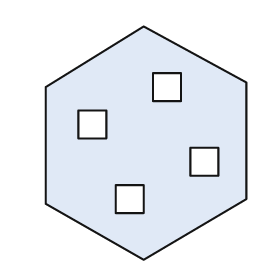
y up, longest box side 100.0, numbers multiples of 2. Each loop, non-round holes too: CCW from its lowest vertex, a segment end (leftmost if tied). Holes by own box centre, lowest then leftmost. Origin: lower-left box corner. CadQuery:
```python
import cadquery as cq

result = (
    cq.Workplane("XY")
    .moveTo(42.0, 0.0)
    .lineTo(86.0, 26.0)
    .lineTo(86.0, 76.0)
    .lineTo(42.0, 100.0)
    .lineTo(0.0, 74.0)
    .lineTo(0.0, 24.0)
    .close()
    .moveTo(30.0, 20.0)
    .lineTo(42.0, 20.0)
    .lineTo(42.0, 32.0)
    .lineTo(30.0, 32.0)
    .close()
    .moveTo(62.0, 36.0)
    .lineTo(74.0, 36.0)
    .lineTo(74.0, 48.0)
    .lineTo(62.0, 48.0)
    .close()
    .moveTo(14.0, 52.0)
    .lineTo(26.0, 52.0)
    .lineTo(26.0, 64.0)
    .lineTo(14.0, 64.0)
    .close()
    .moveTo(46.0, 68.0)
    .lineTo(58.0, 68.0)
    .lineTo(58.0, 80.0)
    .lineTo(46.0, 80.0)
    .close()
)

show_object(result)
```